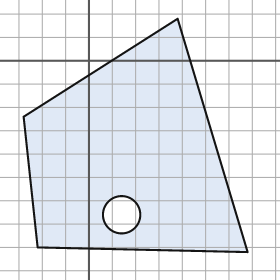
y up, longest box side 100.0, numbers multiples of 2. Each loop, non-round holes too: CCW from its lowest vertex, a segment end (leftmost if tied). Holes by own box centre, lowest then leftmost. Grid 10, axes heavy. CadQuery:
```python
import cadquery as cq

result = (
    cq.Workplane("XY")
    .moveTo(68.0, -82.0)
    .lineTo(38.0, 18.0)
    .lineTo(-28.0, -24.0)
    .lineTo(-22.0, -80.0)
    .close()
    .moveTo(14.0, -66.0)
    .circle(8.0)
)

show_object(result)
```